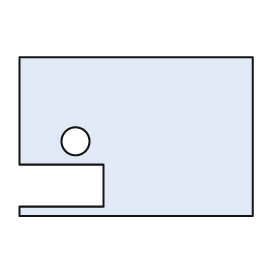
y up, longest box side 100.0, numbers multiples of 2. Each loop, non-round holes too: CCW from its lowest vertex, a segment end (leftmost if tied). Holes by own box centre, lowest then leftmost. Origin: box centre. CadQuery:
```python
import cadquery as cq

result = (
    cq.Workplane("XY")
    .moveTo(-50.0, -34.0)
    .lineTo(50.0, -34.0)
    .lineTo(50.0, 34.0)
    .lineTo(-50.0, 34.0)
    .lineTo(-50.0, -12.0)
    .lineTo(-14.0, -12.0)
    .lineTo(-14.0, -30.0)
    .lineTo(-50.0, -30.0)
    .close()
    .moveTo(-26.0, -2.0)
    .circle(6.0)
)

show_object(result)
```